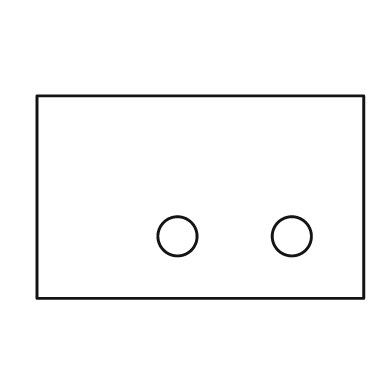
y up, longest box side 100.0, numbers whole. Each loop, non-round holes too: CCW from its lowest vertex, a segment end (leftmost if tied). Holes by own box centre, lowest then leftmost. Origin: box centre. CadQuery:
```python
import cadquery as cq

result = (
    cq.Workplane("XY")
    .moveTo(-50.0, -31.0)
    .lineTo(50.0, -31.0)
    .lineTo(50.0, 31.0)
    .lineTo(-50.0, 31.0)
    .close()
    .moveTo(-7.0, -12.0)
    .circle(6.0)
    .moveTo(28.0, -12.0)
    .circle(6.0)
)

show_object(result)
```